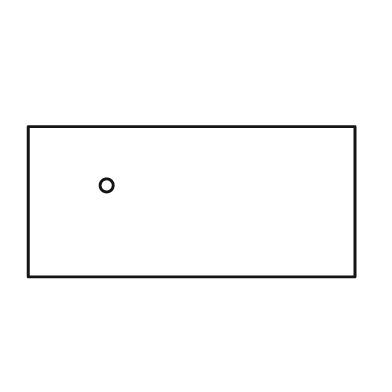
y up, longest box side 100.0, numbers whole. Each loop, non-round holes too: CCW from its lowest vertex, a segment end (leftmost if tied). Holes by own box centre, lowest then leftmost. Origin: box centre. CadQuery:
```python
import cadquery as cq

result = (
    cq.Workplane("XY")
    .moveTo(-50.0, -23.0)
    .lineTo(50.0, -23.0)
    .lineTo(50.0, 23.0)
    .lineTo(-50.0, 23.0)
    .close()
    .moveTo(-26.0, 5.0)
    .circle(2.0)
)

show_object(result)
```